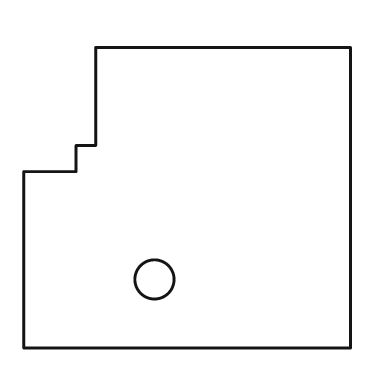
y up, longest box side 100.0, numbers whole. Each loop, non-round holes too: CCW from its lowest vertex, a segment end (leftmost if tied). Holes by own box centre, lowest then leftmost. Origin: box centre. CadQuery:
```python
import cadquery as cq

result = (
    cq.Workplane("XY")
    .moveTo(-50.0, -46.0)
    .lineTo(50.0, -46.0)
    .lineTo(50.0, 46.0)
    .lineTo(-28.0, 46.0)
    .lineTo(-28.0, 16.0)
    .lineTo(-34.0, 16.0)
    .lineTo(-34.0, 8.0)
    .lineTo(-50.0, 8.0)
    .close()
    .moveTo(-10.0, -25.0)
    .circle(6.0)
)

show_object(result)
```